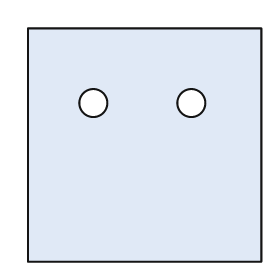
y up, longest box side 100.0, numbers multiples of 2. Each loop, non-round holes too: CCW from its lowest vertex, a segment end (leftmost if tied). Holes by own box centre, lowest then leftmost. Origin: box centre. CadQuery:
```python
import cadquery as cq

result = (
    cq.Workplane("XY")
    .moveTo(-50.0, -50.0)
    .lineTo(50.0, -50.0)
    .lineTo(50.0, 50.0)
    .lineTo(-50.0, 50.0)
    .close()
    .moveTo(-22.0, 18.0)
    .circle(6.0)
    .moveTo(20.0, 18.0)
    .circle(6.0)
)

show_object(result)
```